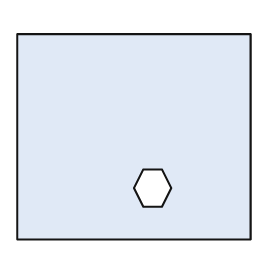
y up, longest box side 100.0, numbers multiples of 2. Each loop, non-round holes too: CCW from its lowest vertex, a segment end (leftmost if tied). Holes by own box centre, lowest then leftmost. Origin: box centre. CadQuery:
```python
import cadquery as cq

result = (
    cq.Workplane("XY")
    .moveTo(-50.0, -44.0)
    .lineTo(50.0, -44.0)
    .lineTo(50.0, 44.0)
    .lineTo(-50.0, 44.0)
    .close()
    .moveTo(4.0, -30.0)
    .lineTo(12.0, -30.0)
    .lineTo(16.0, -22.0)
    .lineTo(12.0, -14.0)
    .lineTo(4.0, -14.0)
    .lineTo(0.0, -22.0)
    .close()
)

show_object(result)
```